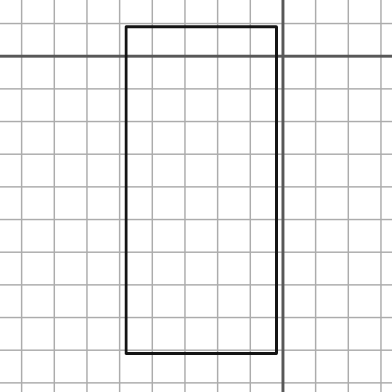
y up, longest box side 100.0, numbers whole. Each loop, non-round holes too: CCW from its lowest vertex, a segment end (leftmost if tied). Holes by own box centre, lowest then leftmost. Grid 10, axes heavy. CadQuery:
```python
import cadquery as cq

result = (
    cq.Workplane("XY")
    .moveTo(-48.0, -91.0)
    .lineTo(-2.0, -91.0)
    .lineTo(-2.0, 9.0)
    .lineTo(-48.0, 9.0)
    .close()
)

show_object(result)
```